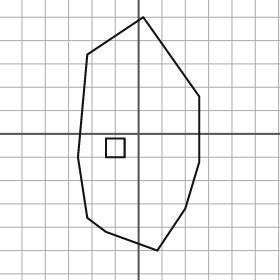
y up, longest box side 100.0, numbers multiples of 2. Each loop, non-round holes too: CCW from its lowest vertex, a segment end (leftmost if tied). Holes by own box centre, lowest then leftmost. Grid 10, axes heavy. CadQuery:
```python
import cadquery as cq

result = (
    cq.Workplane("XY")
    .moveTo(8.0, -50.0)
    .lineTo(20.0, -32.0)
    .lineTo(26.0, -12.0)
    .lineTo(26.0, 16.0)
    .lineTo(2.0, 50.0)
    .lineTo(-22.0, 34.0)
    .lineTo(-26.0, -10.0)
    .lineTo(-22.0, -36.0)
    .lineTo(-14.0, -42.0)
    .close()
    .moveTo(-14.0, -10.0)
    .lineTo(-6.0, -10.0)
    .lineTo(-6.0, -2.0)
    .lineTo(-14.0, -2.0)
    .close()
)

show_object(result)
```